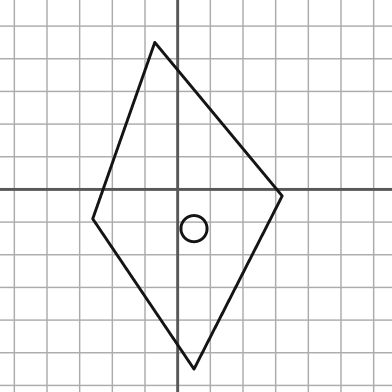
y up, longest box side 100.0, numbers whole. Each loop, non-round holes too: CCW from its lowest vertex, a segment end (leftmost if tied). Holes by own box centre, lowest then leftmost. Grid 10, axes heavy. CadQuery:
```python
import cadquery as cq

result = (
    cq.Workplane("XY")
    .moveTo(5.0, -55.0)
    .lineTo(32.0, -2.0)
    .lineTo(-7.0, 45.0)
    .lineTo(-26.0, -9.0)
    .close()
    .moveTo(5.0, -12.0)
    .circle(4.0)
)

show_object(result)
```